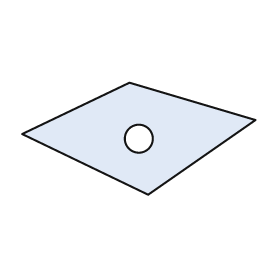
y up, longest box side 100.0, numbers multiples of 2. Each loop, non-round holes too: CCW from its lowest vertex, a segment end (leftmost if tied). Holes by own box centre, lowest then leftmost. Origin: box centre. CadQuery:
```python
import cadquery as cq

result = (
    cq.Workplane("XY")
    .moveTo(4.0, -24.0)
    .lineTo(50.0, 8.0)
    .lineTo(-4.0, 24.0)
    .lineTo(-50.0, 2.0)
    .close()
    .moveTo(0.0, 0.0)
    .circle(6.0)
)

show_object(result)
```